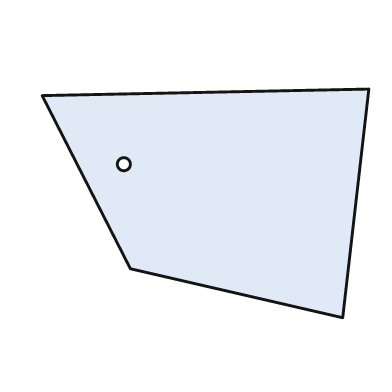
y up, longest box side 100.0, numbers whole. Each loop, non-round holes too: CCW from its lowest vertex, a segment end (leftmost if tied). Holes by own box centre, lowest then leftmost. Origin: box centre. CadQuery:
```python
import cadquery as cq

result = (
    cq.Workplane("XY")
    .moveTo(42.0, -35.0)
    .lineTo(50.0, 35.0)
    .lineTo(-50.0, 33.0)
    .lineTo(-23.0, -20.0)
    .close()
    .moveTo(-25.0, 12.0)
    .circle(2.0)
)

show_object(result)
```